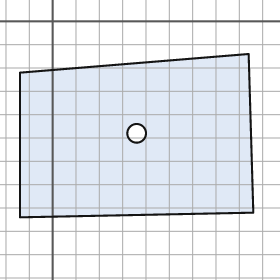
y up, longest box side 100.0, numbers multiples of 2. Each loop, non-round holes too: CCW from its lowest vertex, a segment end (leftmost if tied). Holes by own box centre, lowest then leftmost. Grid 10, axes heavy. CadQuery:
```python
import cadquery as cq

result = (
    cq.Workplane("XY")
    .moveTo(-14.0, -84.0)
    .lineTo(86.0, -82.0)
    .lineTo(84.0, -14.0)
    .lineTo(-14.0, -22.0)
    .close()
    .moveTo(36.0, -48.0)
    .circle(4.0)
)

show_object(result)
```